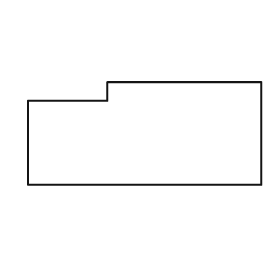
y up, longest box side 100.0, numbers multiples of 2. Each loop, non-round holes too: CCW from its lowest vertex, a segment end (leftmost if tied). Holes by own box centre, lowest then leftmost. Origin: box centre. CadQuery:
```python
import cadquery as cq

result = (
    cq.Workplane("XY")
    .moveTo(-50.0, -22.0)
    .lineTo(50.0, -22.0)
    .lineTo(50.0, 22.0)
    .lineTo(-16.0, 22.0)
    .lineTo(-16.0, 14.0)
    .lineTo(-50.0, 14.0)
    .close()
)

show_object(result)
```